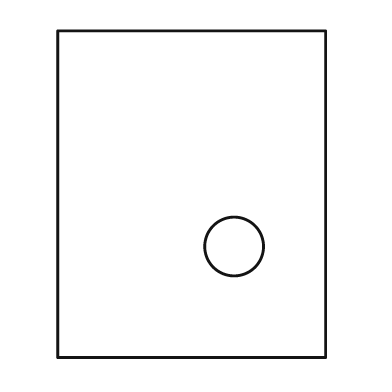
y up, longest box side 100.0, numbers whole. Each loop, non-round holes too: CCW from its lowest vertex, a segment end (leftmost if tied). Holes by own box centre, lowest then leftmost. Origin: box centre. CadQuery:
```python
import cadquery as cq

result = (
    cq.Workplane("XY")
    .moveTo(-41.0, -50.0)
    .lineTo(41.0, -50.0)
    .lineTo(41.0, 50.0)
    .lineTo(-41.0, 50.0)
    .close()
    .moveTo(13.0, -16.0)
    .circle(9.0)
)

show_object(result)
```